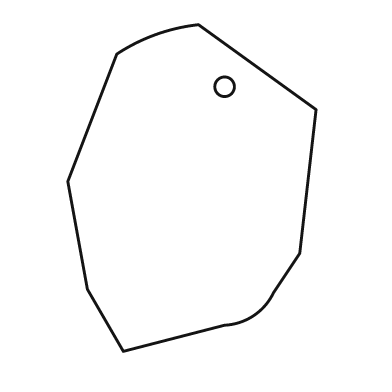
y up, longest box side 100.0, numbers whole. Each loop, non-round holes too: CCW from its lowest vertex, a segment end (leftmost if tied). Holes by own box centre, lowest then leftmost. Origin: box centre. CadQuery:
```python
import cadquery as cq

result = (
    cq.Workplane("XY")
    .moveTo(-21.0, -50.0)
    .lineTo(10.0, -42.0)
    .threePointArc((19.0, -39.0), (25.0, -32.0))
    .lineTo(33.0, -20.0)
    .lineTo(38.0, 24.0)
    .lineTo(2.0, 50.0)
    .threePointArc((-11.0, 47.0), (-23.0, 41.0))
    .lineTo(-38.0, 2.0)
    .lineTo(-32.0, -31.0)
    .close()
    .moveTo(10.0, 31.0)
    .circle(3.0)
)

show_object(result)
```